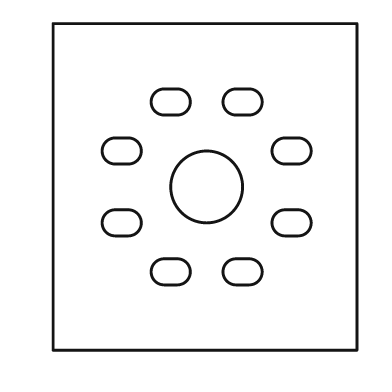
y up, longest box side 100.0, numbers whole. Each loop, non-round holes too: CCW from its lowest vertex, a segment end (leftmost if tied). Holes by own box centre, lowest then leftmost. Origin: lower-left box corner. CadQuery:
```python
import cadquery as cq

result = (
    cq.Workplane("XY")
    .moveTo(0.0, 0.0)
    .lineTo(93.0, 0.0)
    .lineTo(93.0, 100.0)
    .lineTo(0.0, 100.0)
    .close()
    .moveTo(34.0, 20.0)
    .lineTo(38.0, 20.0)
    .threePointArc((42.0, 24.0), (38.0, 28.0))
    .lineTo(34.0, 28.0)
    .threePointArc((30.0, 24.0), (34.0, 20.0))
    .close()
    .moveTo(56.0, 20.0)
    .lineTo(60.0, 20.0)
    .threePointArc((64.0, 24.0), (60.0, 28.0))
    .lineTo(56.0, 28.0)
    .threePointArc((52.0, 24.0), (56.0, 20.0))
    .close()
    .moveTo(19.0, 35.0)
    .lineTo(23.0, 35.0)
    .threePointArc((27.0, 39.0), (23.0, 43.0))
    .lineTo(19.0, 43.0)
    .threePointArc((15.0, 39.0), (19.0, 35.0))
    .close()
    .moveTo(71.0, 35.0)
    .lineTo(75.0, 35.0)
    .threePointArc((79.0, 39.0), (75.0, 43.0))
    .lineTo(71.0, 43.0)
    .threePointArc((67.0, 39.0), (71.0, 35.0))
    .close()
    .moveTo(47.0, 50.0)
    .circle(11.0)
    .moveTo(19.0, 57.0)
    .lineTo(23.0, 57.0)
    .threePointArc((27.0, 61.0), (23.0, 65.0))
    .lineTo(19.0, 65.0)
    .threePointArc((15.0, 61.0), (19.0, 57.0))
    .close()
    .moveTo(71.0, 57.0)
    .lineTo(75.0, 57.0)
    .threePointArc((79.0, 61.0), (75.0, 65.0))
    .lineTo(71.0, 65.0)
    .threePointArc((67.0, 61.0), (71.0, 57.0))
    .close()
    .moveTo(34.0, 72.0)
    .lineTo(38.0, 72.0)
    .threePointArc((42.0, 76.0), (38.0, 80.0))
    .lineTo(34.0, 80.0)
    .threePointArc((30.0, 76.0), (34.0, 72.0))
    .close()
    .moveTo(56.0, 72.0)
    .lineTo(60.0, 72.0)
    .threePointArc((64.0, 76.0), (60.0, 80.0))
    .lineTo(56.0, 80.0)
    .threePointArc((52.0, 76.0), (56.0, 72.0))
    .close()
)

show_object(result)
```